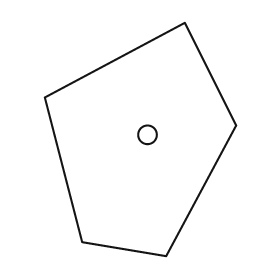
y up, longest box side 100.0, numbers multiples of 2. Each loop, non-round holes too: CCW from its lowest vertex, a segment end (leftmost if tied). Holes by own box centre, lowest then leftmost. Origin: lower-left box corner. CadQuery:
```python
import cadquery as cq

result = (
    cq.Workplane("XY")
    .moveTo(52.0, 0.0)
    .lineTo(82.0, 56.0)
    .lineTo(60.0, 100.0)
    .lineTo(0.0, 68.0)
    .lineTo(16.0, 6.0)
    .close()
    .moveTo(44.0, 52.0)
    .circle(4.0)
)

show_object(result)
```